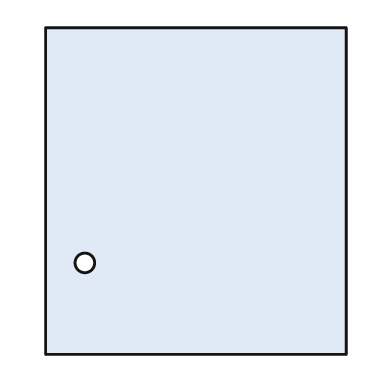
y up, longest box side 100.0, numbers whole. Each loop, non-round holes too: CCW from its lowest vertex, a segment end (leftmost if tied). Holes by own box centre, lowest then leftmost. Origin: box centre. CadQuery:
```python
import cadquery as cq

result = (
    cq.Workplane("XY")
    .moveTo(-46.0, -50.0)
    .lineTo(46.0, -50.0)
    .lineTo(46.0, 50.0)
    .lineTo(-46.0, 50.0)
    .close()
    .moveTo(-34.0, -22.0)
    .circle(3.0)
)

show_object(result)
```